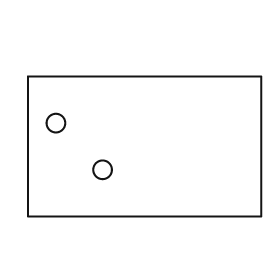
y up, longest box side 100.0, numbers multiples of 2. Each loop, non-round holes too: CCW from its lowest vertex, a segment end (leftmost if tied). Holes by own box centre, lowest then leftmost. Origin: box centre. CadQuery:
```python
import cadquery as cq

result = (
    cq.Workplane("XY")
    .moveTo(-50.0, -30.0)
    .lineTo(50.0, -30.0)
    .lineTo(50.0, 30.0)
    .lineTo(-50.0, 30.0)
    .close()
    .moveTo(-18.0, -10.0)
    .circle(4.0)
    .moveTo(-38.0, 10.0)
    .circle(4.0)
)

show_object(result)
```